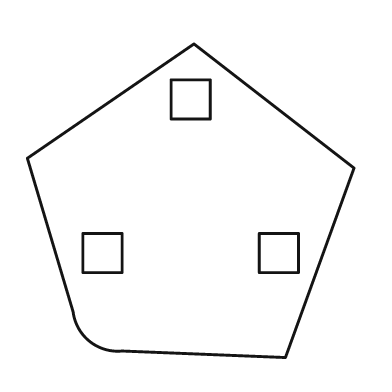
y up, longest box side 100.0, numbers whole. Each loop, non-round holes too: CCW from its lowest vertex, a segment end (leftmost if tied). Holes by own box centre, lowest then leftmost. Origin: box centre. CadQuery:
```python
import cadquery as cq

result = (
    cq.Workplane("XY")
    .moveTo(29.0, -48.0)
    .lineTo(50.0, 10.0)
    .lineTo(1.0, 48.0)
    .lineTo(-50.0, 13.0)
    .lineTo(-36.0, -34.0)
    .threePointArc((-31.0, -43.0), (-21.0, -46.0))
    .close()
    .moveTo(-33.0, -22.0)
    .lineTo(-21.0, -22.0)
    .lineTo(-21.0, -10.0)
    .lineTo(-33.0, -10.0)
    .close()
    .moveTo(21.0, -22.0)
    .lineTo(33.0, -22.0)
    .lineTo(33.0, -10.0)
    .lineTo(21.0, -10.0)
    .close()
    .moveTo(-6.0, 25.0)
    .lineTo(6.0, 25.0)
    .lineTo(6.0, 37.0)
    .lineTo(-6.0, 37.0)
    .close()
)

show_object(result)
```